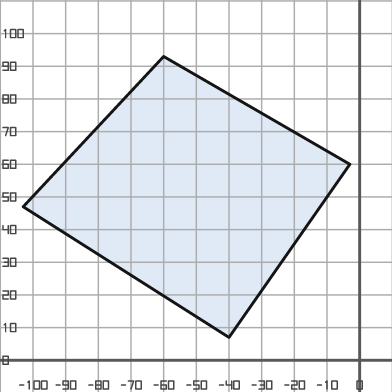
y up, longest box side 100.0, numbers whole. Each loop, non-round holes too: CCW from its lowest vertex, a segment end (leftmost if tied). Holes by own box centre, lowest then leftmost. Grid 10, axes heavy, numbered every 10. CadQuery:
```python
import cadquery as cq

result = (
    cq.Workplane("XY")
    .moveTo(-40.0, 7.0)
    .lineTo(-3.0, 60.0)
    .lineTo(-60.0, 93.0)
    .lineTo(-103.0, 47.0)
    .close()
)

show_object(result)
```